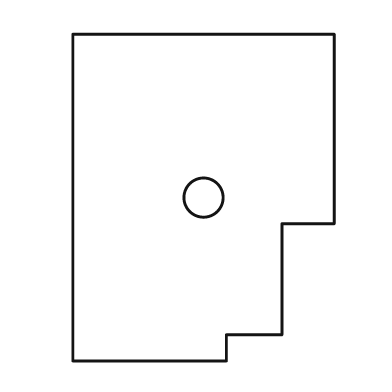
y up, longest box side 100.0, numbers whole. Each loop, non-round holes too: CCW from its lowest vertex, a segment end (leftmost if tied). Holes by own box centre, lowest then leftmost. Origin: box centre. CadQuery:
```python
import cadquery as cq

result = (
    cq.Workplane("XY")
    .moveTo(-40.0, -50.0)
    .lineTo(7.0, -50.0)
    .lineTo(7.0, -42.0)
    .lineTo(24.0, -42.0)
    .lineTo(24.0, -8.0)
    .lineTo(40.0, -8.0)
    .lineTo(40.0, 50.0)
    .lineTo(-40.0, 50.0)
    .close()
    .moveTo(0.0, 0.0)
    .circle(6.0)
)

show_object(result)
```